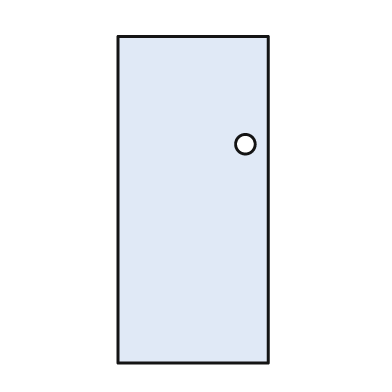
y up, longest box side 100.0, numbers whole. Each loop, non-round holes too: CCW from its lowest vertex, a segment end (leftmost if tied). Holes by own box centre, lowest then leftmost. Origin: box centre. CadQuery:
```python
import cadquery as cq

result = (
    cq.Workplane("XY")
    .moveTo(-23.0, -50.0)
    .lineTo(23.0, -50.0)
    .lineTo(23.0, 50.0)
    .lineTo(-23.0, 50.0)
    .close()
    .moveTo(16.0, 17.0)
    .circle(3.0)
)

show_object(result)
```